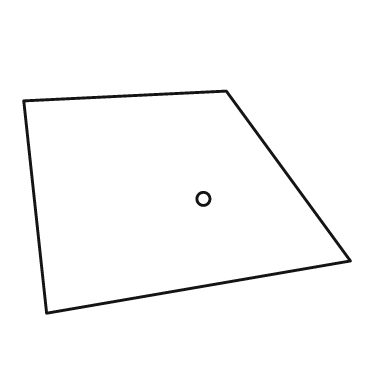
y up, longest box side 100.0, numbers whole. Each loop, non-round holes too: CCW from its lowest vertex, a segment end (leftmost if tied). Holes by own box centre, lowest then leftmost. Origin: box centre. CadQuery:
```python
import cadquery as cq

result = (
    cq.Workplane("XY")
    .moveTo(-43.0, -34.0)
    .lineTo(50.0, -18.0)
    .lineTo(12.0, 34.0)
    .lineTo(-50.0, 31.0)
    .close()
    .moveTo(5.0, 1.0)
    .circle(2.0)
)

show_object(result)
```